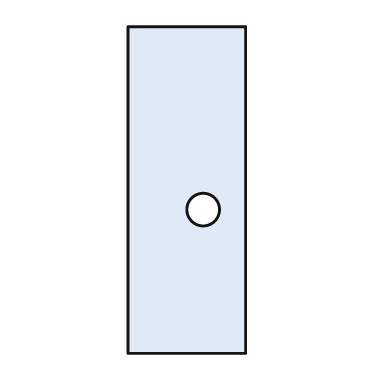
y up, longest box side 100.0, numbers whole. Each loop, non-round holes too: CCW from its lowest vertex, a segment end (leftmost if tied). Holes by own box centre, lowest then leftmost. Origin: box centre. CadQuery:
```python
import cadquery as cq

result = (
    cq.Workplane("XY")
    .moveTo(-18.0, -50.0)
    .lineTo(18.0, -50.0)
    .lineTo(18.0, 50.0)
    .lineTo(-18.0, 50.0)
    .close()
    .moveTo(5.0, -6.0)
    .circle(5.0)
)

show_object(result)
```